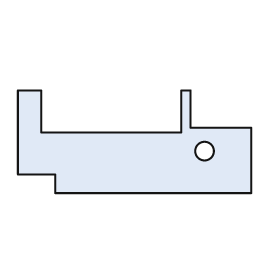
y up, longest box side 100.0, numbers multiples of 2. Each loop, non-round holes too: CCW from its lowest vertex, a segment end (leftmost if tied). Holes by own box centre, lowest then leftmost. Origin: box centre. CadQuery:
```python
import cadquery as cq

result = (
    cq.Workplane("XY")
    .moveTo(-34.0, -22.0)
    .lineTo(50.0, -22.0)
    .lineTo(50.0, 6.0)
    .lineTo(24.0, 6.0)
    .lineTo(24.0, 22.0)
    .lineTo(20.0, 22.0)
    .lineTo(20.0, 4.0)
    .lineTo(-40.0, 4.0)
    .lineTo(-40.0, 22.0)
    .lineTo(-50.0, 22.0)
    .lineTo(-50.0, -14.0)
    .lineTo(-34.0, -14.0)
    .close()
    .moveTo(30.0, -4.0)
    .circle(4.0)
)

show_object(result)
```